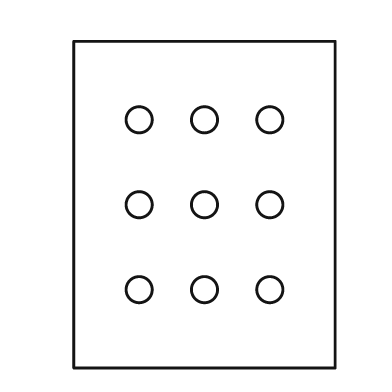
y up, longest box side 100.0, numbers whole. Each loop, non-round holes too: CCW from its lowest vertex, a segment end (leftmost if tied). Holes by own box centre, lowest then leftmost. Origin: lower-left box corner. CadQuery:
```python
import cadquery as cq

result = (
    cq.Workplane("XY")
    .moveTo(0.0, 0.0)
    .lineTo(80.0, 0.0)
    .lineTo(80.0, 100.0)
    .lineTo(0.0, 100.0)
    .close()
    .moveTo(20.0, 24.0)
    .circle(4.0)
    .moveTo(40.0, 24.0)
    .circle(4.0)
    .moveTo(60.0, 24.0)
    .circle(4.0)
    .moveTo(20.0, 50.0)
    .circle(4.0)
    .moveTo(40.0, 50.0)
    .circle(4.0)
    .moveTo(60.0, 50.0)
    .circle(4.0)
    .moveTo(20.0, 76.0)
    .circle(4.0)
    .moveTo(40.0, 76.0)
    .circle(4.0)
    .moveTo(60.0, 76.0)
    .circle(4.0)
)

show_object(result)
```